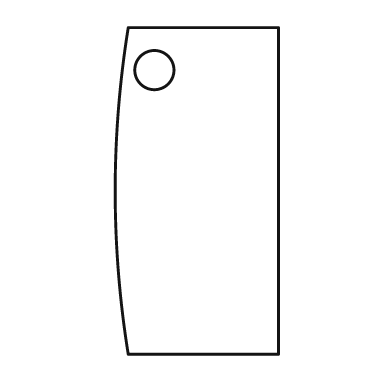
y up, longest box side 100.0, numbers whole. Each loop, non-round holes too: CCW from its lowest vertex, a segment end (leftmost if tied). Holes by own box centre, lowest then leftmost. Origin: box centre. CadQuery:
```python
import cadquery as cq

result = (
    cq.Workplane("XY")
    .moveTo(-21.0, -50.0)
    .lineTo(25.0, -50.0)
    .lineTo(25.0, 50.0)
    .lineTo(-21.0, 50.0)
    .threePointArc((-25.0, 0.0), (-21.0, -50.0))
    .close()
    .moveTo(-13.0, 37.0)
    .circle(6.0)
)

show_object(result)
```